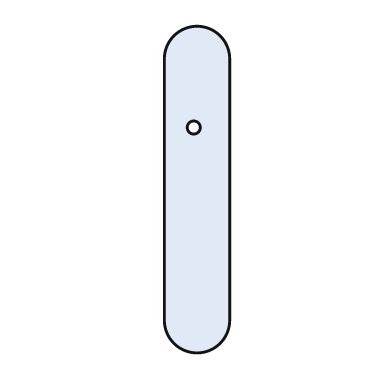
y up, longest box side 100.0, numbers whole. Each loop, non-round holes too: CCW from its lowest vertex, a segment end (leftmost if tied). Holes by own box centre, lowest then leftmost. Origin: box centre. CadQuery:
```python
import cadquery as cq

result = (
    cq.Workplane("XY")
    .moveTo(-10.0, -40.0)
    .threePointArc((0.0, -50.0), (10.0, -40.0))
    .lineTo(10.0, 40.0)
    .threePointArc((0.0, 50.0), (-10.0, 40.0))
    .close()
    .moveTo(-1.0, 19.0)
    .circle(2.0)
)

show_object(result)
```